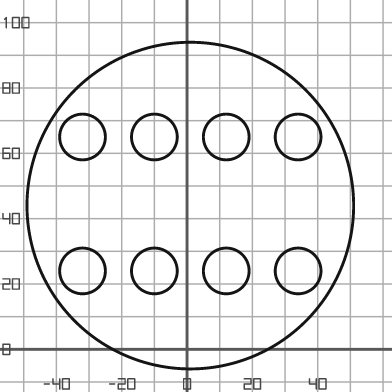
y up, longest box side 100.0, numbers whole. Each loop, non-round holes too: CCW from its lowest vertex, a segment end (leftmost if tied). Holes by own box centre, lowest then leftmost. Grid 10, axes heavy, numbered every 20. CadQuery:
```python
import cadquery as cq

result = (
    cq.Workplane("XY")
    .moveTo(1.0, 44.0)
    .circle(50.0)
    .moveTo(-32.0, 24.0)
    .circle(7.0)
    .moveTo(-10.0, 24.0)
    .circle(7.0)
    .moveTo(12.0, 24.0)
    .circle(7.0)
    .moveTo(34.0, 24.0)
    .circle(7.0)
    .moveTo(-32.0, 65.0)
    .circle(7.0)
    .moveTo(-10.0, 65.0)
    .circle(7.0)
    .moveTo(12.0, 65.0)
    .circle(7.0)
    .moveTo(34.0, 65.0)
    .circle(7.0)
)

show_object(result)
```